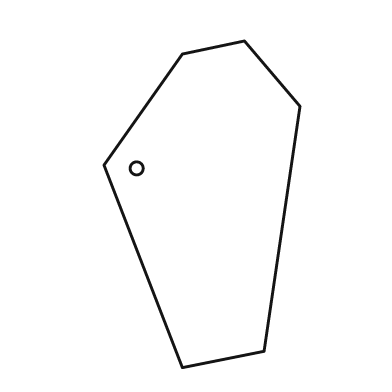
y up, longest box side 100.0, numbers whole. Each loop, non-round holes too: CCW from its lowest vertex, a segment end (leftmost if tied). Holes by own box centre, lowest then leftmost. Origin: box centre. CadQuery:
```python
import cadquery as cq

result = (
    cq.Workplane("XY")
    .moveTo(-6.0, -50.0)
    .lineTo(19.0, -45.0)
    .lineTo(30.0, 30.0)
    .lineTo(13.0, 50.0)
    .lineTo(-6.0, 46.0)
    .lineTo(-30.0, 12.0)
    .close()
    .moveTo(-20.0, 11.0)
    .circle(2.0)
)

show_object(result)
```